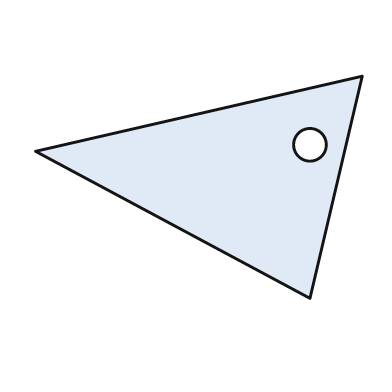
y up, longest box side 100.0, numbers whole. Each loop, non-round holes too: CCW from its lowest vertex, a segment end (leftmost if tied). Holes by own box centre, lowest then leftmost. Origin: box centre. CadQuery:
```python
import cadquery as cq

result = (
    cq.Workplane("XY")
    .moveTo(34.0, -34.0)
    .lineTo(50.0, 34.0)
    .lineTo(-50.0, 11.0)
    .close()
    .moveTo(34.0, 13.0)
    .circle(5.0)
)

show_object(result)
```